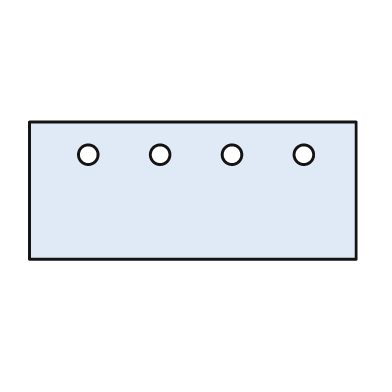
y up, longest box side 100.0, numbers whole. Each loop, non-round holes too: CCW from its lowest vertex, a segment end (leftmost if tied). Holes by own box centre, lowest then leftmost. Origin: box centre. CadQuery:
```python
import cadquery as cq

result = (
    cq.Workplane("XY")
    .moveTo(-50.0, -21.0)
    .lineTo(50.0, -21.0)
    .lineTo(50.0, 21.0)
    .lineTo(-50.0, 21.0)
    .close()
    .moveTo(-32.0, 11.0)
    .circle(3.0)
    .moveTo(-10.0, 11.0)
    .circle(3.0)
    .moveTo(12.0, 11.0)
    .circle(3.0)
    .moveTo(34.0, 11.0)
    .circle(3.0)
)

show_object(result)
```